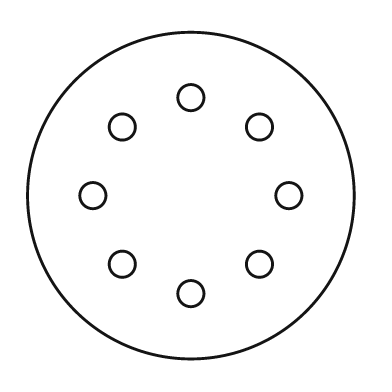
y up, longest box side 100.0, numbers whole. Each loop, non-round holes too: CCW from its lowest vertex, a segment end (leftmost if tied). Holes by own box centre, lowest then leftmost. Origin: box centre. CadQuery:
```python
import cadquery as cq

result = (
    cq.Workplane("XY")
    .moveTo(0.0, 0.0)
    .circle(50.0)
    .moveTo(0.0, -30.0)
    .circle(4.0)
    .moveTo(-21.0, -21.0)
    .circle(4.0)
    .moveTo(21.0, -21.0)
    .circle(4.0)
    .moveTo(-30.0, 0.0)
    .circle(4.0)
    .moveTo(30.0, 0.0)
    .circle(4.0)
    .moveTo(-21.0, 21.0)
    .circle(4.0)
    .moveTo(21.0, 21.0)
    .circle(4.0)
    .moveTo(0.0, 30.0)
    .circle(4.0)
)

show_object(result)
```